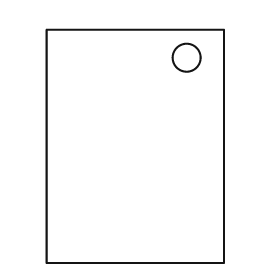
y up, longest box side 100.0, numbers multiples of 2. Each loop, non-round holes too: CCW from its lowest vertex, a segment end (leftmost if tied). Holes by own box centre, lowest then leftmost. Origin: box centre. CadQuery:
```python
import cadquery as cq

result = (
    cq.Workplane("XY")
    .moveTo(-38.0, -50.0)
    .lineTo(38.0, -50.0)
    .lineTo(38.0, 50.0)
    .lineTo(-38.0, 50.0)
    .close()
    .moveTo(22.0, 38.0)
    .circle(6.0)
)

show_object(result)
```